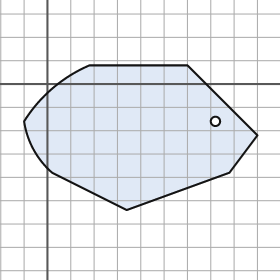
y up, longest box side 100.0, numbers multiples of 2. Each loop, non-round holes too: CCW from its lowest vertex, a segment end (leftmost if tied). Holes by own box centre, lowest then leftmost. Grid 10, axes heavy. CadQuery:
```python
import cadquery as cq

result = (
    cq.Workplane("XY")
    .moveTo(34.0, -54.0)
    .lineTo(78.0, -38.0)
    .lineTo(90.0, -22.0)
    .lineTo(60.0, 8.0)
    .lineTo(18.0, 8.0)
    .threePointArc((2.0, -2.0), (-10.0, -16.0))
    .threePointArc((-6.0, -28.0), (2.0, -38.0))
    .close()
    .moveTo(72.0, -16.0)
    .circle(2.0)
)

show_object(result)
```